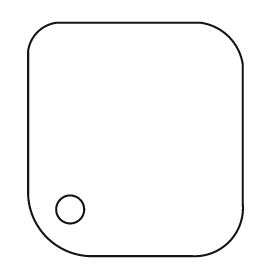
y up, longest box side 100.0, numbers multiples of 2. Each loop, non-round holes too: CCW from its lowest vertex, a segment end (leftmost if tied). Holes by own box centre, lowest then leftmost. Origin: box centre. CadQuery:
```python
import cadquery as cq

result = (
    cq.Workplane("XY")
    .moveTo(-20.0, -50.0)
    .lineTo(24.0, -50.0)
    .threePointArc((40.0, -44.0), (46.0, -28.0))
    .lineTo(46.0, 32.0)
    .threePointArc((40.0, 44.0), (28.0, 50.0))
    .lineTo(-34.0, 50.0)
    .threePointArc((-42.0, 46.0), (-46.0, 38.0))
    .lineTo(-46.0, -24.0)
    .threePointArc((-38.0, -42.0), (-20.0, -50.0))
    .close()
    .moveTo(-28.0, -30.0)
    .circle(6.0)
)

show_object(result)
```